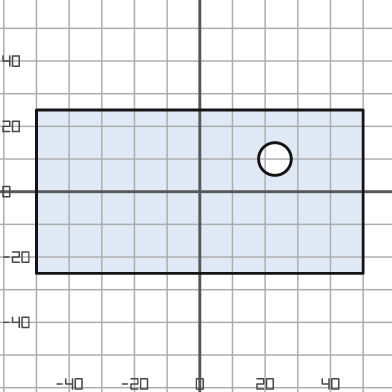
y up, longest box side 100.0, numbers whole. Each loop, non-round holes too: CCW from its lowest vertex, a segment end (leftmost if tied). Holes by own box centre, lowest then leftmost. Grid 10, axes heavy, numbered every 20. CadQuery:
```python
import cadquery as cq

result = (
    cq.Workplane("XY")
    .moveTo(-50.0, -25.0)
    .lineTo(50.0, -25.0)
    .lineTo(50.0, 25.0)
    .lineTo(-50.0, 25.0)
    .close()
    .moveTo(23.0, 10.0)
    .circle(5.0)
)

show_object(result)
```